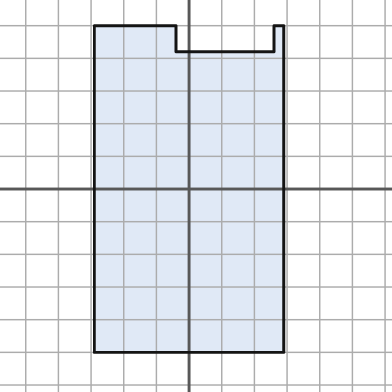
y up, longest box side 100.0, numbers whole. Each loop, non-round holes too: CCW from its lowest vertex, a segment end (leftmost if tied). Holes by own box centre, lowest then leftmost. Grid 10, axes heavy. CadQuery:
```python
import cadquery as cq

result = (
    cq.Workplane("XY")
    .moveTo(-29.0, -50.0)
    .lineTo(29.0, -50.0)
    .lineTo(29.0, 50.0)
    .lineTo(26.0, 50.0)
    .lineTo(26.0, 42.0)
    .lineTo(-4.0, 42.0)
    .lineTo(-4.0, 50.0)
    .lineTo(-29.0, 50.0)
    .close()
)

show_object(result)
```